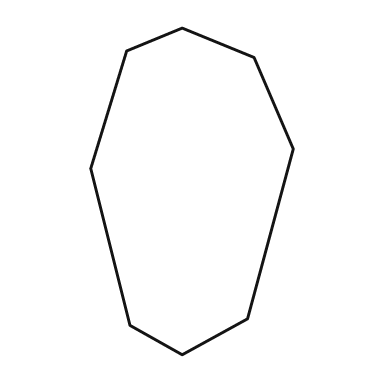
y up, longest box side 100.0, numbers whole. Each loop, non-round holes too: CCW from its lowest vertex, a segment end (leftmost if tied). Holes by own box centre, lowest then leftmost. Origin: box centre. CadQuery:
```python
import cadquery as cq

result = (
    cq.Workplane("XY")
    .moveTo(-3.0, -50.0)
    .lineTo(17.0, -39.0)
    .lineTo(31.0, 13.0)
    .lineTo(19.0, 41.0)
    .lineTo(-3.0, 50.0)
    .lineTo(-20.0, 43.0)
    .lineTo(-31.0, 7.0)
    .lineTo(-19.0, -41.0)
    .close()
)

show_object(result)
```